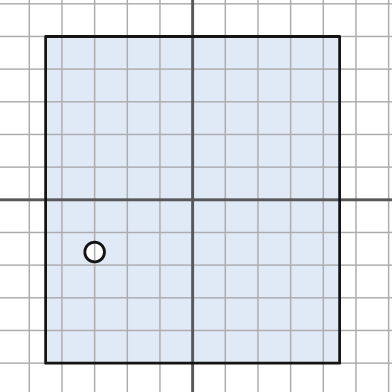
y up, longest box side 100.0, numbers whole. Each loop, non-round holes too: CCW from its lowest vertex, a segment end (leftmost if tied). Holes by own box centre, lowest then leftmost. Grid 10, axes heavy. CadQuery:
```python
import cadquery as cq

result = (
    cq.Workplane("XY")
    .moveTo(-45.0, -50.0)
    .lineTo(45.0, -50.0)
    .lineTo(45.0, 50.0)
    .lineTo(-45.0, 50.0)
    .close()
    .moveTo(-30.0, -16.0)
    .circle(3.0)
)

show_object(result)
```